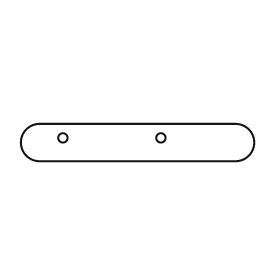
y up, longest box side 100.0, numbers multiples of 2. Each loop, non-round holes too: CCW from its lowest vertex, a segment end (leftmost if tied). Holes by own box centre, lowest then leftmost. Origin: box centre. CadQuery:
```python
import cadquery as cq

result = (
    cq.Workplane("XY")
    .moveTo(-42.0, -8.0)
    .lineTo(42.0, -8.0)
    .threePointArc((50.0, 0.0), (42.0, 8.0))
    .lineTo(-42.0, 8.0)
    .threePointArc((-50.0, 0.0), (-42.0, -8.0))
    .close()
    .moveTo(-32.0, 2.0)
    .circle(2.0)
    .moveTo(10.0, 2.0)
    .circle(2.0)
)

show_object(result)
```